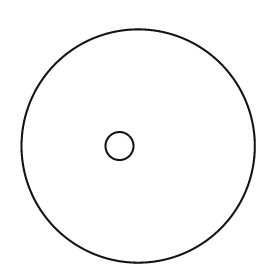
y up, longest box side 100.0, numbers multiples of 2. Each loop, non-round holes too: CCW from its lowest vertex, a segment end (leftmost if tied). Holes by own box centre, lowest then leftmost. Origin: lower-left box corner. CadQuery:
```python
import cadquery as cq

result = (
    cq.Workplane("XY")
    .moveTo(50.0, 50.0)
    .circle(50.0)
    .moveTo(42.0, 50.0)
    .circle(6.0)
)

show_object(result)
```